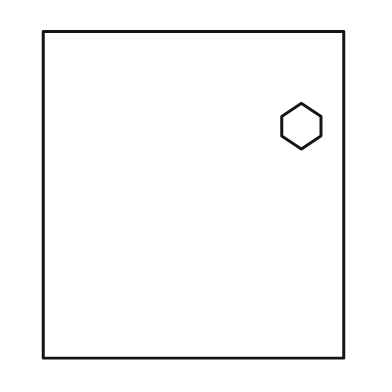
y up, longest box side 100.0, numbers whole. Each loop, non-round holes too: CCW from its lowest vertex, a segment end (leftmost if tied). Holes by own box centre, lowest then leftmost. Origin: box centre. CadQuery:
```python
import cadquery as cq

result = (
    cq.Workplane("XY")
    .moveTo(-46.0, -50.0)
    .lineTo(46.0, -50.0)
    .lineTo(46.0, 50.0)
    .lineTo(-46.0, 50.0)
    .close()
    .moveTo(33.0, 14.0)
    .lineTo(39.0, 18.0)
    .lineTo(39.0, 24.0)
    .lineTo(33.0, 28.0)
    .lineTo(27.0, 24.0)
    .lineTo(27.0, 18.0)
    .close()
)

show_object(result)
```